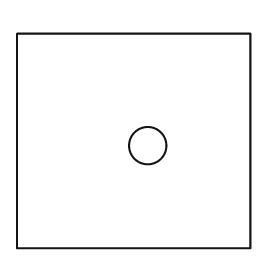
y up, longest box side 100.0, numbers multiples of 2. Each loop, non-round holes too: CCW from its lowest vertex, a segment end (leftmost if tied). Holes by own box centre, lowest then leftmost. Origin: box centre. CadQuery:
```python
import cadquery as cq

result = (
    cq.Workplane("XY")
    .moveTo(-50.0, -46.0)
    .lineTo(50.0, -46.0)
    .lineTo(50.0, 46.0)
    .lineTo(-50.0, 46.0)
    .close()
    .moveTo(6.0, -2.0)
    .circle(8.0)
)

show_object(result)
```